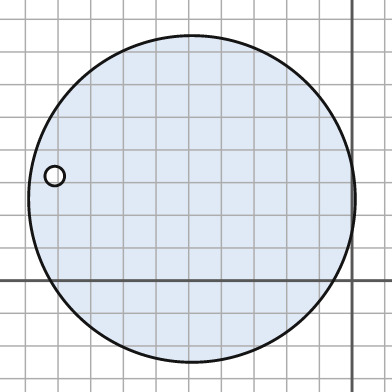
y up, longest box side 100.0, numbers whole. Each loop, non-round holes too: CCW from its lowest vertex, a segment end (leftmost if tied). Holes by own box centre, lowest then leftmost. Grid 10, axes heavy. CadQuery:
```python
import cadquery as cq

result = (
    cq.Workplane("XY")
    .moveTo(-49.0, 25.0)
    .circle(50.0)
    .moveTo(-91.0, 32.0)
    .circle(3.0)
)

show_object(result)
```